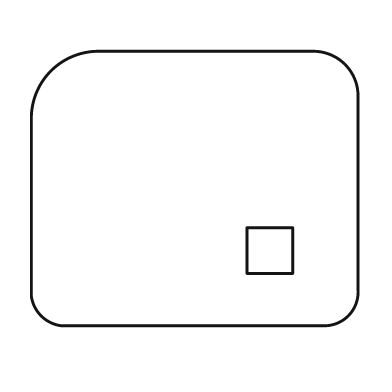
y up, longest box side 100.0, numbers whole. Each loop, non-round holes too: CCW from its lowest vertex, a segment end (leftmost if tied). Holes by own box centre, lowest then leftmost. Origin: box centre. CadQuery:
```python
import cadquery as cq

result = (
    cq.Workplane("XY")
    .moveTo(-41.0, -42.0)
    .lineTo(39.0, -42.0)
    .threePointArc((47.0, -39.0), (50.0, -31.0))
    .lineTo(50.0, 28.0)
    .threePointArc((46.0, 38.0), (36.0, 42.0))
    .lineTo(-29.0, 42.0)
    .threePointArc((-44.0, 36.0), (-50.0, 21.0))
    .lineTo(-50.0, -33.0)
    .threePointArc((-47.0, -39.0), (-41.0, -42.0))
    .close()
    .moveTo(16.0, -26.0)
    .lineTo(30.0, -26.0)
    .lineTo(30.0, -12.0)
    .lineTo(16.0, -12.0)
    .close()
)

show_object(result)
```